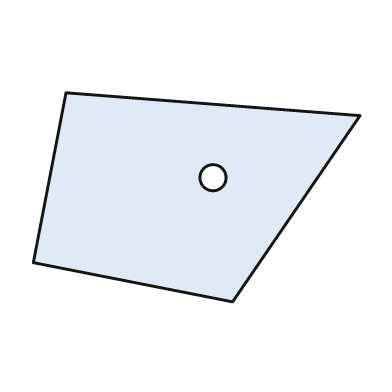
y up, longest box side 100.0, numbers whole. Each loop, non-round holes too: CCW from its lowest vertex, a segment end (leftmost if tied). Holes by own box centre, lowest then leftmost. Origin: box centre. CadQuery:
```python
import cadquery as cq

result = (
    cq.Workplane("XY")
    .moveTo(11.0, -32.0)
    .lineTo(50.0, 25.0)
    .lineTo(-40.0, 32.0)
    .lineTo(-50.0, -20.0)
    .close()
    .moveTo(5.0, 6.0)
    .circle(4.0)
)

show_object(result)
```